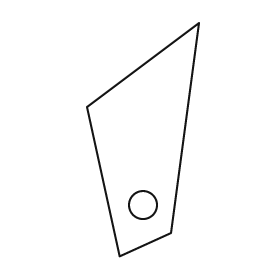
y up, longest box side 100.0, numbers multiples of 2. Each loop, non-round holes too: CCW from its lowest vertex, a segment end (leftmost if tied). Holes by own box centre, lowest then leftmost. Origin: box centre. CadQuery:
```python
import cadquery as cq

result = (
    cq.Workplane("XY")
    .moveTo(-10.0, -50.0)
    .lineTo(12.0, -40.0)
    .lineTo(24.0, 50.0)
    .lineTo(-24.0, 14.0)
    .close()
    .moveTo(0.0, -28.0)
    .circle(6.0)
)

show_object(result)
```